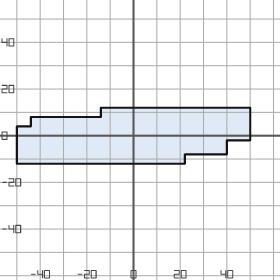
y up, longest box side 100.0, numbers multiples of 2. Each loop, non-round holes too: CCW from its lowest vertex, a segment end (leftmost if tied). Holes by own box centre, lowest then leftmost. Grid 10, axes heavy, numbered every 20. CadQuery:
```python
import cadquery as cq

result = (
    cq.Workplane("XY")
    .moveTo(-50.0, -12.0)
    .lineTo(22.0, -12.0)
    .lineTo(22.0, -8.0)
    .lineTo(40.0, -8.0)
    .lineTo(40.0, -2.0)
    .lineTo(50.0, -2.0)
    .lineTo(50.0, 12.0)
    .lineTo(-14.0, 12.0)
    .lineTo(-14.0, 8.0)
    .lineTo(-44.0, 8.0)
    .lineTo(-44.0, 4.0)
    .lineTo(-50.0, 4.0)
    .close()
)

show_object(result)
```